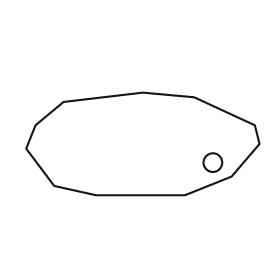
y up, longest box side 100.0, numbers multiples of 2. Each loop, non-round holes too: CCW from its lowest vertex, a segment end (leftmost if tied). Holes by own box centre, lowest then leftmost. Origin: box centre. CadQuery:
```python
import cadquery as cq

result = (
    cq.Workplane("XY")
    .moveTo(-20.0, -22.0)
    .lineTo(18.0, -22.0)
    .lineTo(38.0, -14.0)
    .lineTo(50.0, 0.0)
    .lineTo(48.0, 8.0)
    .lineTo(22.0, 20.0)
    .lineTo(0.0, 22.0)
    .lineTo(-34.0, 18.0)
    .lineTo(-46.0, 8.0)
    .lineTo(-50.0, -2.0)
    .lineTo(-38.0, -18.0)
    .close()
    .moveTo(30.0, -8.0)
    .circle(4.0)
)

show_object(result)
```